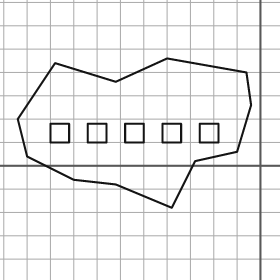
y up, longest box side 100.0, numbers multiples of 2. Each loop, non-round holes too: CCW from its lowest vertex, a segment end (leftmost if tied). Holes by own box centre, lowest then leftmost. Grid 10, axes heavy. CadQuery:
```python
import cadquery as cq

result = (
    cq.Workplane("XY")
    .moveTo(-38.0, -18.0)
    .lineTo(-28.0, 2.0)
    .lineTo(-10.0, 6.0)
    .lineTo(-4.0, 26.0)
    .lineTo(-6.0, 40.0)
    .lineTo(-40.0, 46.0)
    .lineTo(-62.0, 36.0)
    .lineTo(-88.0, 44.0)
    .lineTo(-104.0, 20.0)
    .lineTo(-100.0, 4.0)
    .lineTo(-80.0, -6.0)
    .lineTo(-62.0, -8.0)
    .close()
    .moveTo(-90.0, 10.0)
    .lineTo(-82.0, 10.0)
    .lineTo(-82.0, 18.0)
    .lineTo(-90.0, 18.0)
    .close()
    .moveTo(-74.0, 10.0)
    .lineTo(-66.0, 10.0)
    .lineTo(-66.0, 18.0)
    .lineTo(-74.0, 18.0)
    .close()
    .moveTo(-58.0, 10.0)
    .lineTo(-50.0, 10.0)
    .lineTo(-50.0, 18.0)
    .lineTo(-58.0, 18.0)
    .close()
    .moveTo(-42.0, 10.0)
    .lineTo(-34.0, 10.0)
    .lineTo(-34.0, 18.0)
    .lineTo(-42.0, 18.0)
    .close()
    .moveTo(-26.0, 10.0)
    .lineTo(-18.0, 10.0)
    .lineTo(-18.0, 18.0)
    .lineTo(-26.0, 18.0)
    .close()
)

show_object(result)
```